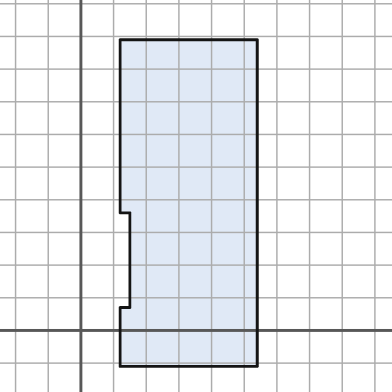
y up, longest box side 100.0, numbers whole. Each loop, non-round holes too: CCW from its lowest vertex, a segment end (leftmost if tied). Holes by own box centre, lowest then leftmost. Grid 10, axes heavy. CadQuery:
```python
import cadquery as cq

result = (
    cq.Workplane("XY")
    .moveTo(12.0, -11.0)
    .lineTo(54.0, -11.0)
    .lineTo(54.0, 89.0)
    .lineTo(12.0, 89.0)
    .lineTo(12.0, 36.0)
    .lineTo(15.0, 36.0)
    .lineTo(15.0, 7.0)
    .lineTo(12.0, 7.0)
    .close()
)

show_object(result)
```